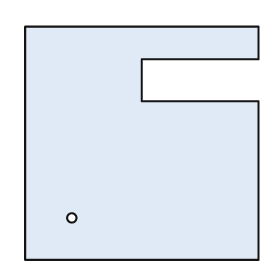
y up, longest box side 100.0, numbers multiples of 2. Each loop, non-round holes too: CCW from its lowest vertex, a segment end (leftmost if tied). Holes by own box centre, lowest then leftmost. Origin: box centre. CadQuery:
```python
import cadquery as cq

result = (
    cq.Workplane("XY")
    .moveTo(-50.0, -50.0)
    .lineTo(50.0, -50.0)
    .lineTo(50.0, 18.0)
    .lineTo(0.0, 18.0)
    .lineTo(0.0, 36.0)
    .lineTo(50.0, 36.0)
    .lineTo(50.0, 50.0)
    .lineTo(-50.0, 50.0)
    .close()
    .moveTo(-30.0, -32.0)
    .circle(2.0)
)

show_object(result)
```